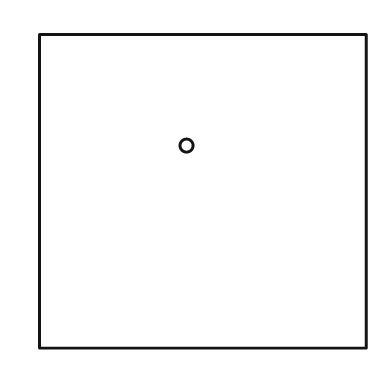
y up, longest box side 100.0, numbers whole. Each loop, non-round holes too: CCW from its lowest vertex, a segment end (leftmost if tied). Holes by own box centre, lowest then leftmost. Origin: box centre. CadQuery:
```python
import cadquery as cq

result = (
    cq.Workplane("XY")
    .moveTo(-50.0, -48.0)
    .lineTo(50.0, -48.0)
    .lineTo(50.0, 48.0)
    .lineTo(-50.0, 48.0)
    .close()
    .moveTo(-5.0, 14.0)
    .circle(2.0)
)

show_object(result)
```